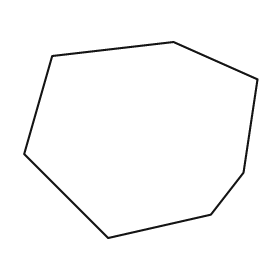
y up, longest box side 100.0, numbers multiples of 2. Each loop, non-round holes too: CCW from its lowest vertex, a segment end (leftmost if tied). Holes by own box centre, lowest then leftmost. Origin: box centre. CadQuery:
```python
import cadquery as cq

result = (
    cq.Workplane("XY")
    .moveTo(-14.0, -42.0)
    .lineTo(30.0, -32.0)
    .lineTo(44.0, -14.0)
    .lineTo(50.0, 26.0)
    .lineTo(14.0, 42.0)
    .lineTo(-38.0, 36.0)
    .lineTo(-50.0, -6.0)
    .close()
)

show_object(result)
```